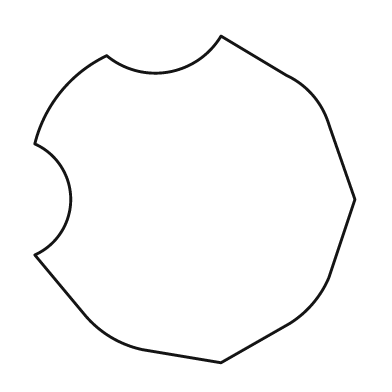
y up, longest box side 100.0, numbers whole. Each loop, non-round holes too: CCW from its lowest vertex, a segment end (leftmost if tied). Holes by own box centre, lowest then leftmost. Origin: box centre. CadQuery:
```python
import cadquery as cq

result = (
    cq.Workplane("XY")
    .moveTo(8.0, -50.0)
    .lineTo(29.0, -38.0)
    .threePointArc((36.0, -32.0), (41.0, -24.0))
    .lineTo(49.0, 0.0)
    .lineTo(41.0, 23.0)
    .threePointArc((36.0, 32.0), (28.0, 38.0))
    .lineTo(8.0, 50.0)
    .threePointArc((-8.0, 39.0), (-27.0, 44.0))
    .threePointArc((-41.0, 33.0), (-49.0, 17.0))
    .threePointArc((-38.0, 0.0), (-49.0, -17.0))
    .lineTo(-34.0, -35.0)
    .threePointArc((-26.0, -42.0), (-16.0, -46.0))
    .close()
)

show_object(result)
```